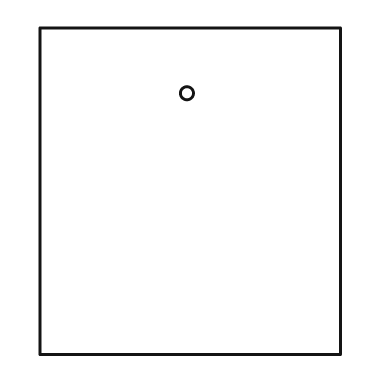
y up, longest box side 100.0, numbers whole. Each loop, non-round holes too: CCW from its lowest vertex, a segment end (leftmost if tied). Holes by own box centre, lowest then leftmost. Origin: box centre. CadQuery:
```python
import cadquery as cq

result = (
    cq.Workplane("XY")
    .moveTo(-46.0, -50.0)
    .lineTo(46.0, -50.0)
    .lineTo(46.0, 50.0)
    .lineTo(-46.0, 50.0)
    .close()
    .moveTo(-1.0, 30.0)
    .circle(2.0)
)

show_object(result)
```